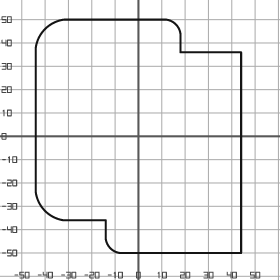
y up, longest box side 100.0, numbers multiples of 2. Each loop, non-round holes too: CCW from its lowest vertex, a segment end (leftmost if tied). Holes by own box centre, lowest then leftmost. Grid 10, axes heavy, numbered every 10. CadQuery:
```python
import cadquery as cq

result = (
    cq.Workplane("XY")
    .moveTo(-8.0, -50.0)
    .lineTo(44.0, -50.0)
    .lineTo(44.0, 36.0)
    .lineTo(18.0, 36.0)
    .lineTo(18.0, 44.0)
    .threePointArc((16.0, 48.0), (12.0, 50.0))
    .lineTo(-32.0, 50.0)
    .threePointArc((-40.0, 46.0), (-44.0, 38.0))
    .lineTo(-44.0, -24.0)
    .threePointArc((-40.0, -32.0), (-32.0, -36.0))
    .lineTo(-14.0, -36.0)
    .lineTo(-14.0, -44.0)
    .threePointArc((-12.0, -48.0), (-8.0, -50.0))
    .close()
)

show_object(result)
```